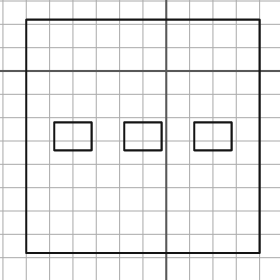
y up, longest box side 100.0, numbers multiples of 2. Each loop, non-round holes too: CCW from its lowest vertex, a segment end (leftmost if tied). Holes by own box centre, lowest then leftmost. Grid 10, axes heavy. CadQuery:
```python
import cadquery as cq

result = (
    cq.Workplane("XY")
    .moveTo(-60.0, -78.0)
    .lineTo(40.0, -78.0)
    .lineTo(40.0, 22.0)
    .lineTo(-60.0, 22.0)
    .close()
    .moveTo(-48.0, -34.0)
    .lineTo(-32.0, -34.0)
    .lineTo(-32.0, -22.0)
    .lineTo(-48.0, -22.0)
    .close()
    .moveTo(-18.0, -34.0)
    .lineTo(-2.0, -34.0)
    .lineTo(-2.0, -22.0)
    .lineTo(-18.0, -22.0)
    .close()
    .moveTo(12.0, -34.0)
    .lineTo(28.0, -34.0)
    .lineTo(28.0, -22.0)
    .lineTo(12.0, -22.0)
    .close()
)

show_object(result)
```